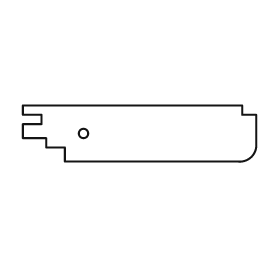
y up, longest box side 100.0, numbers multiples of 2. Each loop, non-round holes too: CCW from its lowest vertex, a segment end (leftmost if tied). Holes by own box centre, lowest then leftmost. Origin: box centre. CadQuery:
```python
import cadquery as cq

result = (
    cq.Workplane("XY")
    .moveTo(-32.0, -12.0)
    .lineTo(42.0, -12.0)
    .threePointArc((48.0, -10.0), (50.0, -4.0))
    .lineTo(50.0, 8.0)
    .lineTo(44.0, 8.0)
    .lineTo(44.0, 12.0)
    .lineTo(-50.0, 12.0)
    .lineTo(-50.0, 8.0)
    .lineTo(-42.0, 8.0)
    .lineTo(-42.0, 4.0)
    .lineTo(-50.0, 4.0)
    .lineTo(-50.0, -2.0)
    .lineTo(-40.0, -2.0)
    .lineTo(-40.0, -6.0)
    .lineTo(-32.0, -6.0)
    .close()
    .moveTo(-24.0, 0.0)
    .circle(2.0)
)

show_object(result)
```